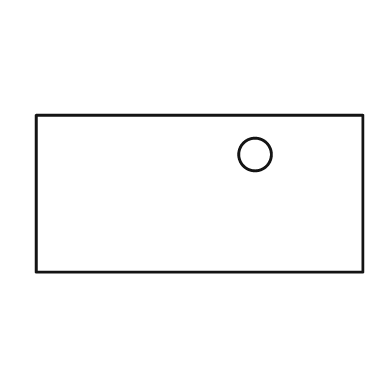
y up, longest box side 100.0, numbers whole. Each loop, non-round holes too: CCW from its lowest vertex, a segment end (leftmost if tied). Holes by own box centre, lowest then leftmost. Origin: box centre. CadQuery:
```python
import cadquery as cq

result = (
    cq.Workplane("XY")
    .moveTo(-50.0, -24.0)
    .lineTo(50.0, -24.0)
    .lineTo(50.0, 24.0)
    .lineTo(-50.0, 24.0)
    .close()
    .moveTo(17.0, 12.0)
    .circle(5.0)
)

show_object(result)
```